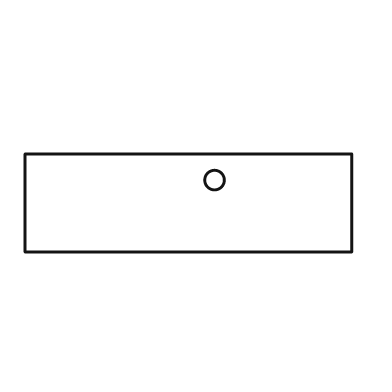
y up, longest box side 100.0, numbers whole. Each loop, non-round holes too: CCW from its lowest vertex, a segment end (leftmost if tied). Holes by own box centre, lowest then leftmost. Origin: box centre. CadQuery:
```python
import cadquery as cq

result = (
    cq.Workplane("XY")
    .moveTo(-50.0, -15.0)
    .lineTo(50.0, -15.0)
    .lineTo(50.0, 15.0)
    .lineTo(-50.0, 15.0)
    .close()
    .moveTo(8.0, 7.0)
    .circle(3.0)
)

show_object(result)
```